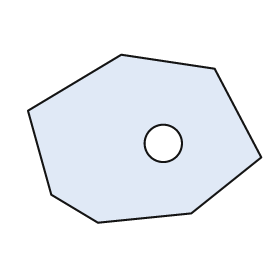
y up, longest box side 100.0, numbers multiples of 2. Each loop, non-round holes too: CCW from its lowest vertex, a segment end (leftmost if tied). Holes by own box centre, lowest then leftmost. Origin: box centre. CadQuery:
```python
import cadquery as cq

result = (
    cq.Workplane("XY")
    .moveTo(-20.0, -36.0)
    .lineTo(20.0, -32.0)
    .lineTo(50.0, -8.0)
    .lineTo(30.0, 30.0)
    .lineTo(-10.0, 36.0)
    .lineTo(-50.0, 12.0)
    .lineTo(-40.0, -24.0)
    .close()
    .moveTo(8.0, -2.0)
    .circle(8.0)
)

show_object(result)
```